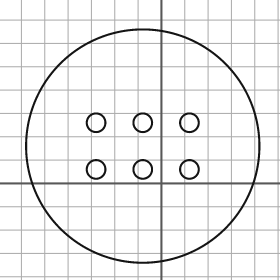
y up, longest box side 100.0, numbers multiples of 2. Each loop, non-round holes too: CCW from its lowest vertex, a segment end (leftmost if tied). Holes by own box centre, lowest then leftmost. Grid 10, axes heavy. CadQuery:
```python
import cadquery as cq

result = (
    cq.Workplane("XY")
    .moveTo(-8.0, 16.0)
    .circle(50.0)
    .moveTo(-28.0, 6.0)
    .circle(4.0)
    .moveTo(-8.0, 6.0)
    .circle(4.0)
    .moveTo(12.0, 6.0)
    .circle(4.0)
    .moveTo(-28.0, 26.0)
    .circle(4.0)
    .moveTo(-8.0, 26.0)
    .circle(4.0)
    .moveTo(12.0, 26.0)
    .circle(4.0)
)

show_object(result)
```